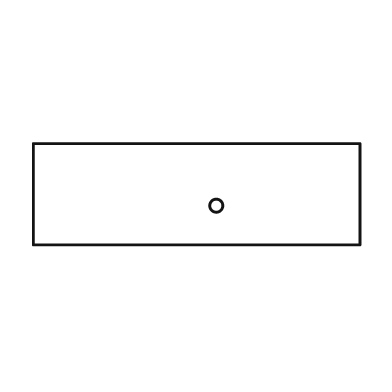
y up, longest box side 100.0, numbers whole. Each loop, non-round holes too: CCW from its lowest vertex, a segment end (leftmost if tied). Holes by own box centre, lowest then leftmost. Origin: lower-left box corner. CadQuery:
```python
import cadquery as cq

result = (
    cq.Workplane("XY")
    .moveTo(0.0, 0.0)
    .lineTo(100.0, 0.0)
    .lineTo(100.0, 31.0)
    .lineTo(0.0, 31.0)
    .close()
    .moveTo(56.0, 12.0)
    .circle(2.0)
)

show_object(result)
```